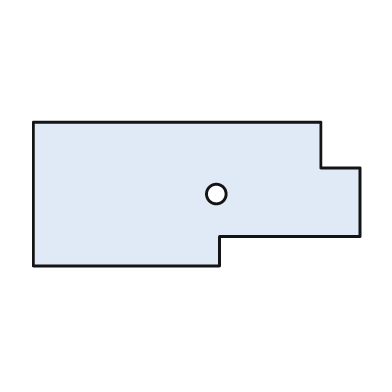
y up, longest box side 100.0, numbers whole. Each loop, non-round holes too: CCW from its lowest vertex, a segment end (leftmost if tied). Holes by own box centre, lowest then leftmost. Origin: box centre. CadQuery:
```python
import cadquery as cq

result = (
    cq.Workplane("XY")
    .moveTo(-50.0, -22.0)
    .lineTo(7.0, -22.0)
    .lineTo(7.0, -13.0)
    .lineTo(50.0, -13.0)
    .lineTo(50.0, 8.0)
    .lineTo(38.0, 8.0)
    .lineTo(38.0, 22.0)
    .lineTo(-50.0, 22.0)
    .close()
    .moveTo(6.0, 0.0)
    .circle(3.0)
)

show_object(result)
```